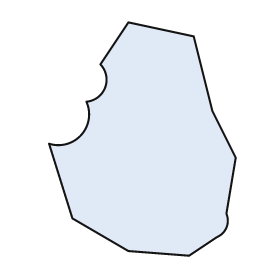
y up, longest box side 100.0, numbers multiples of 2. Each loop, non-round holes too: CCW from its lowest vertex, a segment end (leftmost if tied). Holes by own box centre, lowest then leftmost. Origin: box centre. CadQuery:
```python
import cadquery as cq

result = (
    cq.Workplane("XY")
    .moveTo(20.0, -50.0)
    .lineTo(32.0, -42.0)
    .threePointArc((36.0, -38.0), (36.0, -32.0))
    .lineTo(40.0, -8.0)
    .lineTo(30.0, 12.0)
    .lineTo(22.0, 44.0)
    .lineTo(-6.0, 50.0)
    .lineTo(-18.0, 32.0)
    .threePointArc((-16.0, 22.0), (-24.0, 16.0))
    .threePointArc((-26.0, 2.0), (-40.0, -2.0))
    .lineTo(-30.0, -34.0)
    .lineTo(-6.0, -48.0)
    .close()
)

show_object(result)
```